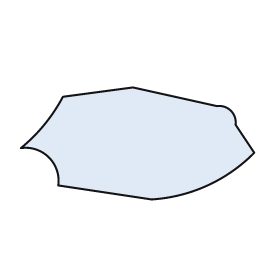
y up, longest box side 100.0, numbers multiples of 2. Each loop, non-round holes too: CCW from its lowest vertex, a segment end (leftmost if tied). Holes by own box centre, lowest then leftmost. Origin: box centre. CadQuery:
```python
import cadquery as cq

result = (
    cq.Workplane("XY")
    .moveTo(6.0, -24.0)
    .threePointArc((30.0, -18.0), (50.0, -4.0))
    .lineTo(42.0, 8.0)
    .threePointArc((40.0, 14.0), (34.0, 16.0))
    .lineTo(-2.0, 24.0)
    .lineTo(-32.0, 20.0)
    .threePointArc((-40.0, 8.0), (-50.0, -2.0))
    .threePointArc((-38.0, -6.0), (-34.0, -18.0))
    .close()
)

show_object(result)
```